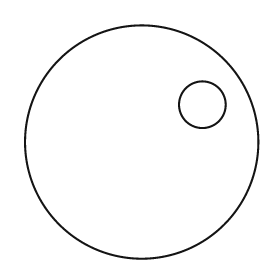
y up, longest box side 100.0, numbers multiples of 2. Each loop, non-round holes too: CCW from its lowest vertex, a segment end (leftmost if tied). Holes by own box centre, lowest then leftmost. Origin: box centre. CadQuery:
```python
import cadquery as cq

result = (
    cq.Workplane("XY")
    .moveTo(0.0, 0.0)
    .circle(50.0)
    .moveTo(26.0, 16.0)
    .circle(10.0)
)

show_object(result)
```